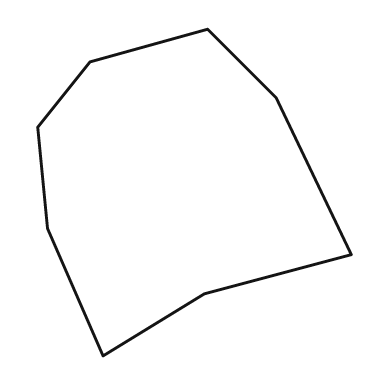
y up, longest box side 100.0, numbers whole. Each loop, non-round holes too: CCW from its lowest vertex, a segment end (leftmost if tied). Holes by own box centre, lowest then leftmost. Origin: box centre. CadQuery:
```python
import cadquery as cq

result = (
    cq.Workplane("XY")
    .moveTo(-28.0, -50.0)
    .lineTo(3.0, -31.0)
    .lineTo(48.0, -19.0)
    .lineTo(25.0, 29.0)
    .lineTo(4.0, 50.0)
    .lineTo(-32.0, 40.0)
    .lineTo(-48.0, 20.0)
    .lineTo(-45.0, -11.0)
    .close()
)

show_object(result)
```